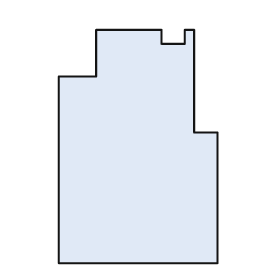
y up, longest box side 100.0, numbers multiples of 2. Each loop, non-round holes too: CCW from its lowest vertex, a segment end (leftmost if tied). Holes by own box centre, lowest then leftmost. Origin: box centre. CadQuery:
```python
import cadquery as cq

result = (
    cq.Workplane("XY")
    .moveTo(-34.0, -50.0)
    .lineTo(34.0, -50.0)
    .lineTo(34.0, 6.0)
    .lineTo(24.0, 6.0)
    .lineTo(24.0, 50.0)
    .lineTo(20.0, 50.0)
    .lineTo(20.0, 44.0)
    .lineTo(10.0, 44.0)
    .lineTo(10.0, 50.0)
    .lineTo(-18.0, 50.0)
    .lineTo(-18.0, 30.0)
    .lineTo(-34.0, 30.0)
    .close()
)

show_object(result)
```